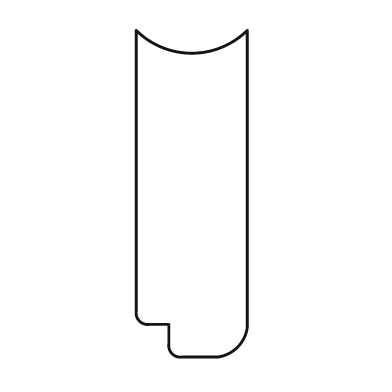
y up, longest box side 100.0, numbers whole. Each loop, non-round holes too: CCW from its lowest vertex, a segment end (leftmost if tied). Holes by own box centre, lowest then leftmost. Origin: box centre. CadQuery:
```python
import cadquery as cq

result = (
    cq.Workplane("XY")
    .moveTo(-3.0, -50.0)
    .lineTo(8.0, -50.0)
    .threePointArc((14.0, -47.0), (17.0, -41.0))
    .lineTo(17.0, 50.0)
    .threePointArc((0.0, 43.0), (-17.0, 50.0))
    .lineTo(-17.0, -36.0)
    .threePointArc((-16.0, -39.0), (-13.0, -40.0))
    .lineTo(-7.0, -40.0)
    .lineTo(-7.0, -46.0)
    .threePointArc((-6.0, -49.0), (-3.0, -50.0))
    .close()
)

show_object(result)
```